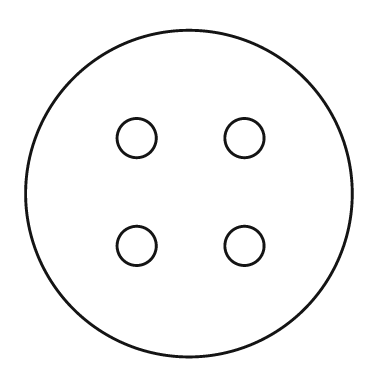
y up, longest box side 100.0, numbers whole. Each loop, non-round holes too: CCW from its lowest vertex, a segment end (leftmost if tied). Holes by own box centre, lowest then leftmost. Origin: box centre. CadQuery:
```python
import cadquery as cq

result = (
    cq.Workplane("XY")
    .moveTo(0.0, 0.0)
    .circle(50.0)
    .moveTo(-16.0, -16.0)
    .circle(6.0)
    .moveTo(17.0, -16.0)
    .circle(6.0)
    .moveTo(-16.0, 17.0)
    .circle(6.0)
    .moveTo(17.0, 17.0)
    .circle(6.0)
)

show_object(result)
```